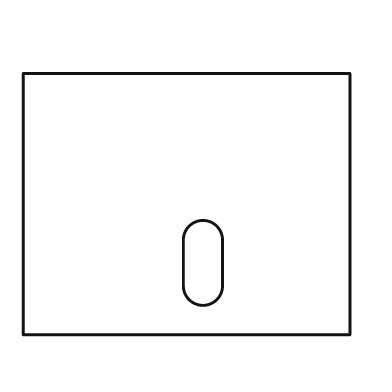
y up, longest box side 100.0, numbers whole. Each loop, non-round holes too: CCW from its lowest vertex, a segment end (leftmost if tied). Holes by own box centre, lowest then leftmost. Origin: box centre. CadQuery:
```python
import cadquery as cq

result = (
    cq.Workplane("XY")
    .moveTo(-50.0, -40.0)
    .lineTo(50.0, -40.0)
    .lineTo(50.0, 40.0)
    .lineTo(-50.0, 40.0)
    .close()
    .moveTo(-1.0, -25.0)
    .threePointArc((5.0, -31.0), (11.0, -25.0))
    .lineTo(11.0, -11.0)
    .threePointArc((5.0, -5.0), (-1.0, -11.0))
    .close()
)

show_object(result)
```